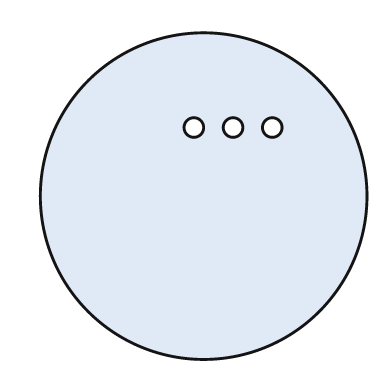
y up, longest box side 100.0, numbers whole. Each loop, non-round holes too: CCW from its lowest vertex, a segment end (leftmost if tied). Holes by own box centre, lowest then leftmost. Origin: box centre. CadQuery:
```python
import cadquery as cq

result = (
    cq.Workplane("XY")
    .moveTo(0.0, 0.0)
    .circle(50.0)
    .moveTo(-3.0, 21.0)
    .circle(3.0)
    .moveTo(9.0, 21.0)
    .circle(3.0)
    .moveTo(21.0, 21.0)
    .circle(3.0)
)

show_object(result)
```